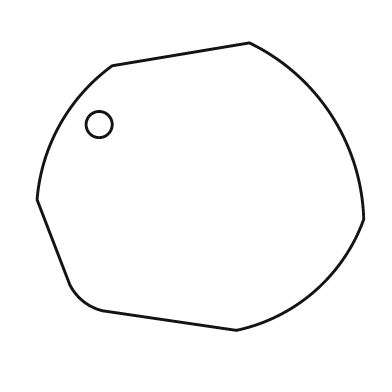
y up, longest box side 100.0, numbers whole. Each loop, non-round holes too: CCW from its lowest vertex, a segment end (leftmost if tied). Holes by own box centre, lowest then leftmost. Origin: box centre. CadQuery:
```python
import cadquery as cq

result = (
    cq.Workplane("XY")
    .moveTo(11.0, -44.0)
    .threePointArc((35.0, -32.0), (50.0, -10.0))
    .threePointArc((40.0, 22.0), (15.0, 44.0))
    .lineTo(-27.0, 37.0)
    .threePointArc((-43.0, 19.0), (-50.0, -4.0))
    .lineTo(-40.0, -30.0)
    .threePointArc((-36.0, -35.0), (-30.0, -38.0))
    .close()
    .moveTo(-31.0, 19.0)
    .circle(4.0)
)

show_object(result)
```